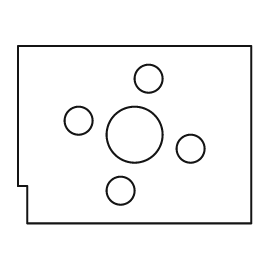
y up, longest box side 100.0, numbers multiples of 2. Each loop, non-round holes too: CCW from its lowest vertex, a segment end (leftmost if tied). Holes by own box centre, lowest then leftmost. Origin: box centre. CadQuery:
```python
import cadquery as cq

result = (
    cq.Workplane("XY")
    .moveTo(-46.0, -38.0)
    .lineTo(50.0, -38.0)
    .lineTo(50.0, 38.0)
    .lineTo(-50.0, 38.0)
    .lineTo(-50.0, -22.0)
    .lineTo(-46.0, -22.0)
    .close()
    .moveTo(-6.0, -24.0)
    .circle(6.0)
    .moveTo(24.0, -6.0)
    .circle(6.0)
    .moveTo(0.0, 0.0)
    .circle(12.0)
    .moveTo(-24.0, 6.0)
    .circle(6.0)
    .moveTo(6.0, 24.0)
    .circle(6.0)
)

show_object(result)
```